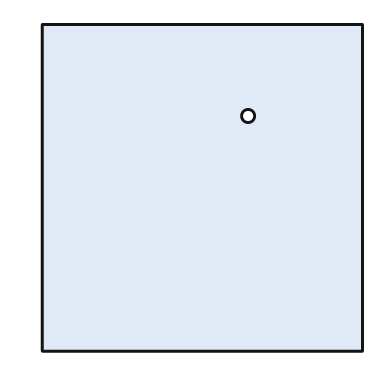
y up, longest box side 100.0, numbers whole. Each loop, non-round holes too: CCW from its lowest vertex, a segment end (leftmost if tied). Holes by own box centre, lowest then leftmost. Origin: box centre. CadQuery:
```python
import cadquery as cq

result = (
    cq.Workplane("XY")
    .moveTo(-49.0, -50.0)
    .lineTo(49.0, -50.0)
    .lineTo(49.0, 50.0)
    .lineTo(-49.0, 50.0)
    .close()
    .moveTo(14.0, 22.0)
    .circle(2.0)
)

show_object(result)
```